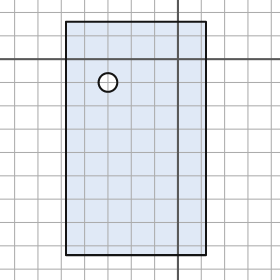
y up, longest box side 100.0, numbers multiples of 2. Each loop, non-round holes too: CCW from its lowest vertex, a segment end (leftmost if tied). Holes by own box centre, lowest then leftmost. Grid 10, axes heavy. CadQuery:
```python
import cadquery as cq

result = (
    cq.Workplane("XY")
    .moveTo(-48.0, -84.0)
    .lineTo(12.0, -84.0)
    .lineTo(12.0, 16.0)
    .lineTo(-48.0, 16.0)
    .close()
    .moveTo(-30.0, -10.0)
    .circle(4.0)
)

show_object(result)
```